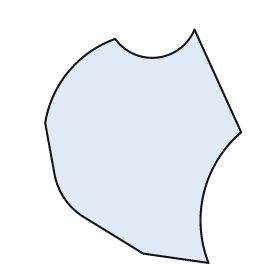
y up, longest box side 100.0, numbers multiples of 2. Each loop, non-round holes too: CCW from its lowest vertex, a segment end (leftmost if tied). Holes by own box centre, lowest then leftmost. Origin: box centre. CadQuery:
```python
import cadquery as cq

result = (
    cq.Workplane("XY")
    .moveTo(28.0, -50.0)
    .threePointArc((26.0, -20.0), (42.0, 6.0))
    .lineTo(22.0, 50.0)
    .threePointArc((6.0, 38.0), (-12.0, 46.0))
    .threePointArc((-32.0, 32.0), (-42.0, 10.0))
    .lineTo(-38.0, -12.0)
    .threePointArc((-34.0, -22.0), (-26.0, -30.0))
    .lineTo(0.0, -46.0)
    .close()
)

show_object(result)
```